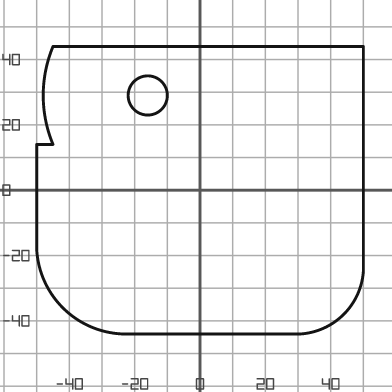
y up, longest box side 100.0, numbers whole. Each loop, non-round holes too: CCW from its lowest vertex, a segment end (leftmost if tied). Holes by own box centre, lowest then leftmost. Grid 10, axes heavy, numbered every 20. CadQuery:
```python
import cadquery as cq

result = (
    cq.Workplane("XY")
    .moveTo(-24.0, -44.0)
    .lineTo(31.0, -44.0)
    .threePointArc((44.0, -38.0), (50.0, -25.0))
    .lineTo(50.0, 44.0)
    .lineTo(-45.0, 44.0)
    .threePointArc((-48.0, 29.0), (-45.0, 14.0))
    .lineTo(-50.0, 14.0)
    .lineTo(-50.0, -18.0)
    .threePointArc((-42.0, -36.0), (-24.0, -44.0))
    .close()
    .moveTo(-16.0, 29.0)
    .circle(6.0)
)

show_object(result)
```